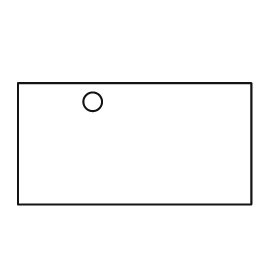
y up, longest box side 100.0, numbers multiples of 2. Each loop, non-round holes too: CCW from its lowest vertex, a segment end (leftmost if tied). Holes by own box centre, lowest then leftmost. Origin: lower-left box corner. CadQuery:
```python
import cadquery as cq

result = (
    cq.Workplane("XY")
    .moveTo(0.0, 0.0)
    .lineTo(100.0, 0.0)
    .lineTo(100.0, 52.0)
    .lineTo(0.0, 52.0)
    .close()
    .moveTo(32.0, 44.0)
    .circle(4.0)
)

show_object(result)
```